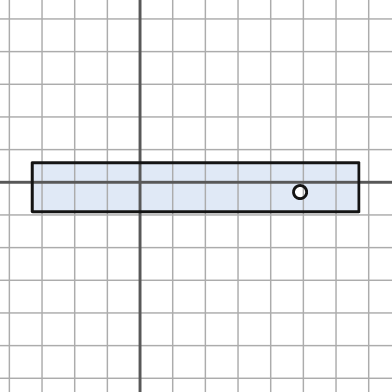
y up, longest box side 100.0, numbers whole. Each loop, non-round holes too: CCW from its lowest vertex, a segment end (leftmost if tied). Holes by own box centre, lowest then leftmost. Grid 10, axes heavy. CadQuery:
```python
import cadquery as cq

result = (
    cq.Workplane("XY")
    .moveTo(-33.0, -9.0)
    .lineTo(67.0, -9.0)
    .lineTo(67.0, 6.0)
    .lineTo(-33.0, 6.0)
    .close()
    .moveTo(49.0, -3.0)
    .circle(2.0)
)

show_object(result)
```